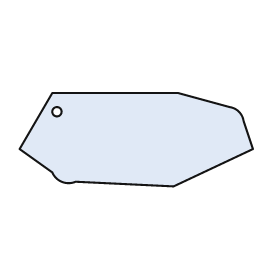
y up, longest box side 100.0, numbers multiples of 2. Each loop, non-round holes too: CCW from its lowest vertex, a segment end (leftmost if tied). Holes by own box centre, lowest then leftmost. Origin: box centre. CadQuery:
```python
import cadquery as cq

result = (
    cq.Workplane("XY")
    .moveTo(16.0, -20.0)
    .lineTo(50.0, -4.0)
    .lineTo(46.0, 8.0)
    .threePointArc((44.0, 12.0), (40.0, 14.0))
    .lineTo(18.0, 20.0)
    .lineTo(-36.0, 20.0)
    .lineTo(-50.0, -4.0)
    .lineTo(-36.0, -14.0)
    .threePointArc((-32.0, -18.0), (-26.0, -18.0))
    .close()
    .moveTo(-34.0, 12.0)
    .circle(2.0)
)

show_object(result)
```